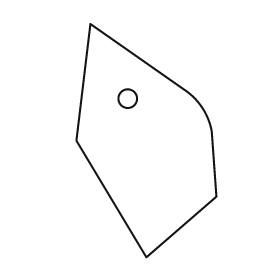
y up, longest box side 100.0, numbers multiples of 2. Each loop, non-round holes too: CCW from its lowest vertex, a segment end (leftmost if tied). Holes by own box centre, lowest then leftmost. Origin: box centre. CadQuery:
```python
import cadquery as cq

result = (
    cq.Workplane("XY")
    .moveTo(0.0, -50.0)
    .lineTo(30.0, -24.0)
    .lineTo(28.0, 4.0)
    .threePointArc((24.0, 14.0), (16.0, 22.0))
    .lineTo(-24.0, 50.0)
    .lineTo(-30.0, 0.0)
    .close()
    .moveTo(-8.0, 18.0)
    .circle(4.0)
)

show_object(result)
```